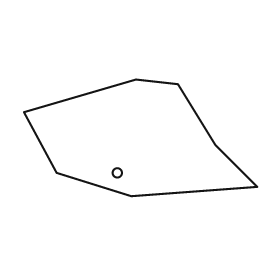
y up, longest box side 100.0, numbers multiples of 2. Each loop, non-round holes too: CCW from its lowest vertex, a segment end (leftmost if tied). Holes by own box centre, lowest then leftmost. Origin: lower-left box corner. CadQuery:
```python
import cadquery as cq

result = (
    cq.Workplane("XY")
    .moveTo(46.0, 0.0)
    .lineTo(100.0, 4.0)
    .lineTo(82.0, 22.0)
    .lineTo(66.0, 48.0)
    .lineTo(48.0, 50.0)
    .lineTo(0.0, 36.0)
    .lineTo(14.0, 10.0)
    .close()
    .moveTo(40.0, 10.0)
    .circle(2.0)
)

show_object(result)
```